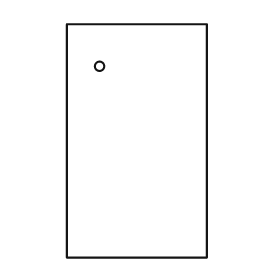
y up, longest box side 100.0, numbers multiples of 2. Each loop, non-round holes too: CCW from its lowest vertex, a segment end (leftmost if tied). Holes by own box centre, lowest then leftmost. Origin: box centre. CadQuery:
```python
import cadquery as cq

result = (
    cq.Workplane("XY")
    .moveTo(-30.0, -50.0)
    .lineTo(30.0, -50.0)
    .lineTo(30.0, 50.0)
    .lineTo(-30.0, 50.0)
    .close()
    .moveTo(-16.0, 32.0)
    .circle(2.0)
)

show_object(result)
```